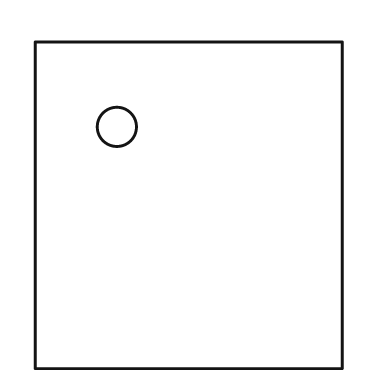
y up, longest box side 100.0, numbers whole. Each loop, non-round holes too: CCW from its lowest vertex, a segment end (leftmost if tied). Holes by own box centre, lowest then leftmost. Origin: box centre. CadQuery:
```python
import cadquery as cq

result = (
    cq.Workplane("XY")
    .moveTo(-47.0, -50.0)
    .lineTo(47.0, -50.0)
    .lineTo(47.0, 50.0)
    .lineTo(-47.0, 50.0)
    .close()
    .moveTo(-22.0, 24.0)
    .circle(6.0)
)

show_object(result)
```